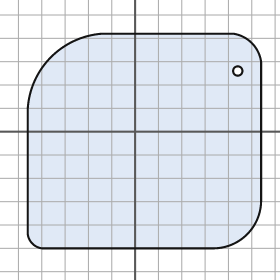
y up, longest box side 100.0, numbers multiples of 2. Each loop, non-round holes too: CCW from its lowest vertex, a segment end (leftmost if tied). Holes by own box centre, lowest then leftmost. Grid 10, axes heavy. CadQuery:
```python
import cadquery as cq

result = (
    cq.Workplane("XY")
    .moveTo(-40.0, -50.0)
    .lineTo(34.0, -50.0)
    .threePointArc((48.0, -44.0), (54.0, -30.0))
    .lineTo(54.0, 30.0)
    .threePointArc((50.0, 38.0), (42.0, 42.0))
    .lineTo(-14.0, 42.0)
    .threePointArc((-36.0, 32.0), (-46.0, 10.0))
    .lineTo(-46.0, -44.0)
    .threePointArc((-44.0, -48.0), (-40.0, -50.0))
    .close()
    .moveTo(44.0, 26.0)
    .circle(2.0)
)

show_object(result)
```